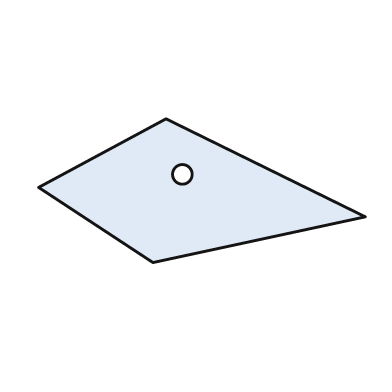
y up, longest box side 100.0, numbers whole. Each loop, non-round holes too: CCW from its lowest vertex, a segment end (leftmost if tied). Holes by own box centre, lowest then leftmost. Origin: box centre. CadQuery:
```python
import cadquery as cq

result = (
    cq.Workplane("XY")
    .moveTo(-15.0, -22.0)
    .lineTo(50.0, -8.0)
    .lineTo(-11.0, 22.0)
    .lineTo(-50.0, 1.0)
    .close()
    .moveTo(-6.0, 5.0)
    .circle(3.0)
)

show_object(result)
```